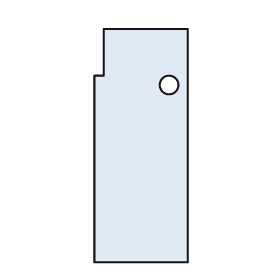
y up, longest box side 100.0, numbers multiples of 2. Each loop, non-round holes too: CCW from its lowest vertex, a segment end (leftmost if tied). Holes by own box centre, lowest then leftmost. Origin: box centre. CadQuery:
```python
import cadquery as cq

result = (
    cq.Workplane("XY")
    .moveTo(-20.0, -50.0)
    .lineTo(20.0, -50.0)
    .lineTo(20.0, 50.0)
    .lineTo(-16.0, 50.0)
    .lineTo(-16.0, 30.0)
    .lineTo(-20.0, 30.0)
    .close()
    .moveTo(12.0, 26.0)
    .circle(4.0)
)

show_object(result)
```